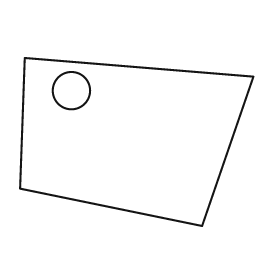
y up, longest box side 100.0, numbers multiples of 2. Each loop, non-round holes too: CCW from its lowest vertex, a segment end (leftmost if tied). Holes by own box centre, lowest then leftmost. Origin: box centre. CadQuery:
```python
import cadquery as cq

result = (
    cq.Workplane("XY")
    .moveTo(28.0, -36.0)
    .lineTo(50.0, 28.0)
    .lineTo(-48.0, 36.0)
    .lineTo(-50.0, -20.0)
    .close()
    .moveTo(-28.0, 22.0)
    .circle(8.0)
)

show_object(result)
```